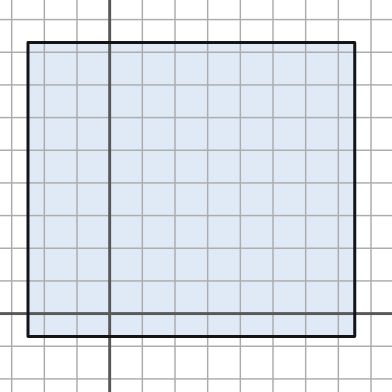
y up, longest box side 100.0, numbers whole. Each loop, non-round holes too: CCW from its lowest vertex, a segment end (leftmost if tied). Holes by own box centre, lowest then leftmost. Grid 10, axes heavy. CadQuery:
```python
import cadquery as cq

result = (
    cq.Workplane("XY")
    .moveTo(-25.0, -7.0)
    .lineTo(75.0, -7.0)
    .lineTo(75.0, 83.0)
    .lineTo(-25.0, 83.0)
    .close()
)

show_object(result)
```